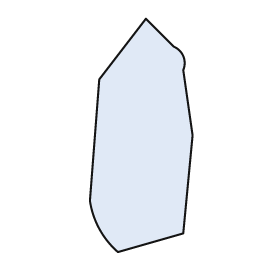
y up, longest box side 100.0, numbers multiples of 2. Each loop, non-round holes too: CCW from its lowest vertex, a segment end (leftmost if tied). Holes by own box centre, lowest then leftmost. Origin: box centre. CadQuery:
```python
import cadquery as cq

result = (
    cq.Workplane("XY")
    .moveTo(-10.0, -50.0)
    .lineTo(18.0, -42.0)
    .lineTo(22.0, 0.0)
    .lineTo(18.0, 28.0)
    .threePointArc((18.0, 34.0), (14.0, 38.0))
    .lineTo(2.0, 50.0)
    .lineTo(-18.0, 24.0)
    .lineTo(-22.0, -28.0)
    .threePointArc((-18.0, -40.0), (-10.0, -50.0))
    .close()
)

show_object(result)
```